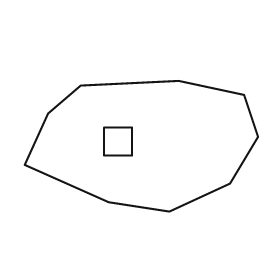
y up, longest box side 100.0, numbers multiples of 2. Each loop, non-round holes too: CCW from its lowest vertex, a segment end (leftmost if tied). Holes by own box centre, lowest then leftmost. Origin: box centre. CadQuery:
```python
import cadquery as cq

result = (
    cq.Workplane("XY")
    .moveTo(12.0, -28.0)
    .lineTo(38.0, -16.0)
    .lineTo(50.0, 4.0)
    .lineTo(44.0, 22.0)
    .lineTo(16.0, 28.0)
    .lineTo(-26.0, 26.0)
    .lineTo(-40.0, 14.0)
    .lineTo(-50.0, -8.0)
    .lineTo(-14.0, -24.0)
    .close()
    .moveTo(-16.0, -4.0)
    .lineTo(-4.0, -4.0)
    .lineTo(-4.0, 8.0)
    .lineTo(-16.0, 8.0)
    .close()
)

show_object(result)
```